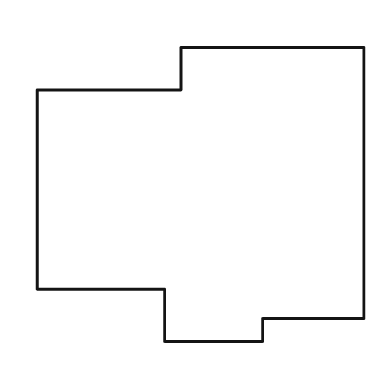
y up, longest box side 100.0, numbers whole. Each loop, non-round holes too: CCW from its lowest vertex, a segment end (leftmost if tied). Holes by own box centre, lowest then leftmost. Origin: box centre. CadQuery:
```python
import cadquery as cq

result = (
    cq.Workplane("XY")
    .moveTo(-11.0, -45.0)
    .lineTo(19.0, -45.0)
    .lineTo(19.0, -38.0)
    .lineTo(50.0, -38.0)
    .lineTo(50.0, 45.0)
    .lineTo(-6.0, 45.0)
    .lineTo(-6.0, 32.0)
    .lineTo(-50.0, 32.0)
    .lineTo(-50.0, -29.0)
    .lineTo(-11.0, -29.0)
    .close()
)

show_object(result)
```